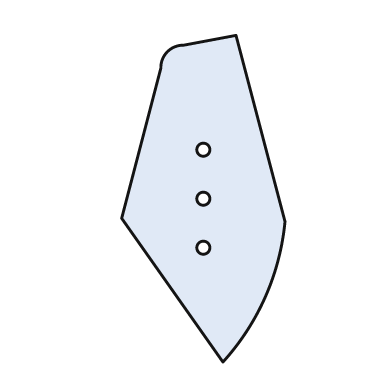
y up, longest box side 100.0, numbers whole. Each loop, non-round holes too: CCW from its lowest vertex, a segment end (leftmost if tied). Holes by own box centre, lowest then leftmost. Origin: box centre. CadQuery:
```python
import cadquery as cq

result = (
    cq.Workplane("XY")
    .moveTo(6.0, -50.0)
    .threePointArc((19.0, -30.0), (25.0, -7.0))
    .lineTo(10.0, 50.0)
    .lineTo(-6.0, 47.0)
    .threePointArc((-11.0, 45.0), (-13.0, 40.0))
    .lineTo(-25.0, -6.0)
    .close()
    .moveTo(0.0, -15.0)
    .circle(2.0)
    .moveTo(0.0, 0.0)
    .circle(2.0)
    .moveTo(0.0, 15.0)
    .circle(2.0)
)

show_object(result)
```